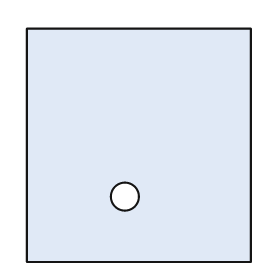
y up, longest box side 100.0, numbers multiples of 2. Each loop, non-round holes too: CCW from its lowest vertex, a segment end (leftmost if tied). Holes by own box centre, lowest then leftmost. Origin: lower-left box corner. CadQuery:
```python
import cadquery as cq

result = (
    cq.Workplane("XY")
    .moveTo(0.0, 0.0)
    .lineTo(96.0, 0.0)
    .lineTo(96.0, 100.0)
    .lineTo(0.0, 100.0)
    .close()
    .moveTo(42.0, 28.0)
    .circle(6.0)
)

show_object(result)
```